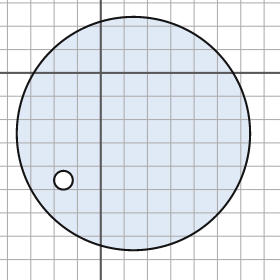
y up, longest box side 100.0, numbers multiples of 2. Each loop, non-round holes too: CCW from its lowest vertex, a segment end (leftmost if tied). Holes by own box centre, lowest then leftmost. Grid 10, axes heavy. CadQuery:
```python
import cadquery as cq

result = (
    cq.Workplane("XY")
    .moveTo(14.0, -26.0)
    .circle(50.0)
    .moveTo(-16.0, -46.0)
    .circle(4.0)
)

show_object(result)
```